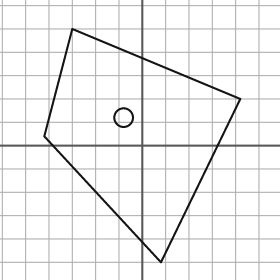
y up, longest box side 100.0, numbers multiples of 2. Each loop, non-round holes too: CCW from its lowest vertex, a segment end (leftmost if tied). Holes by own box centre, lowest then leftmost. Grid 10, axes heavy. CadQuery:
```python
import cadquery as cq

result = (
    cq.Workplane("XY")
    .moveTo(8.0, -50.0)
    .lineTo(42.0, 20.0)
    .lineTo(-30.0, 50.0)
    .lineTo(-42.0, 4.0)
    .close()
    .moveTo(-8.0, 12.0)
    .circle(4.0)
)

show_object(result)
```